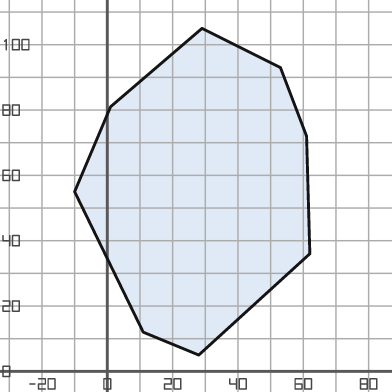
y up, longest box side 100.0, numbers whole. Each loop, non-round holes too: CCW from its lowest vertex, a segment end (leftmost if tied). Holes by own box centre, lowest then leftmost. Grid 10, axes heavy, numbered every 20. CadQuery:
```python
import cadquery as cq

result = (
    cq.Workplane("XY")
    .moveTo(28.0, 5.0)
    .lineTo(62.0, 36.0)
    .lineTo(61.0, 72.0)
    .lineTo(53.0, 93.0)
    .lineTo(29.0, 105.0)
    .lineTo(1.0, 81.0)
    .lineTo(-10.0, 55.0)
    .lineTo(11.0, 12.0)
    .close()
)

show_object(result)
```